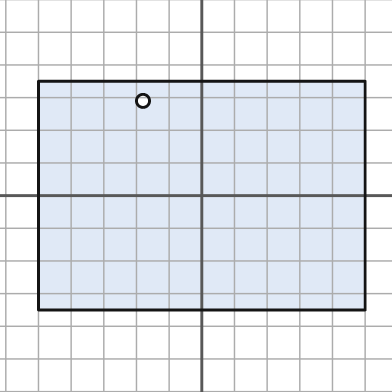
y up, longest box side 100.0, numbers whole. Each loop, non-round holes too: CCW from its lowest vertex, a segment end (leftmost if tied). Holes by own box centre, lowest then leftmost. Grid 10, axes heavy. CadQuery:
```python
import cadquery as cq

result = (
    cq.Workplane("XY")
    .moveTo(-50.0, -35.0)
    .lineTo(50.0, -35.0)
    .lineTo(50.0, 35.0)
    .lineTo(-50.0, 35.0)
    .close()
    .moveTo(-18.0, 29.0)
    .circle(2.0)
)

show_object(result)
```